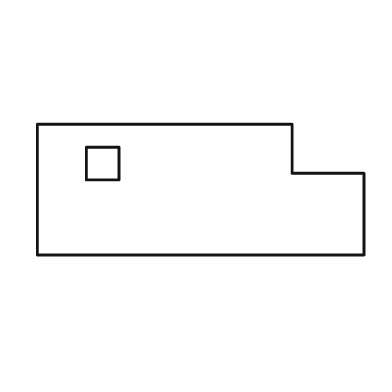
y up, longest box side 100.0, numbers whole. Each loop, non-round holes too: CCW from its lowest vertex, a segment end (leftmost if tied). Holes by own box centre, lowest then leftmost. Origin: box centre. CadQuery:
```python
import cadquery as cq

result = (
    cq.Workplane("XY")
    .moveTo(-50.0, -20.0)
    .lineTo(50.0, -20.0)
    .lineTo(50.0, 5.0)
    .lineTo(28.0, 5.0)
    .lineTo(28.0, 20.0)
    .lineTo(-50.0, 20.0)
    .close()
    .moveTo(-35.0, 3.0)
    .lineTo(-25.0, 3.0)
    .lineTo(-25.0, 13.0)
    .lineTo(-35.0, 13.0)
    .close()
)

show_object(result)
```